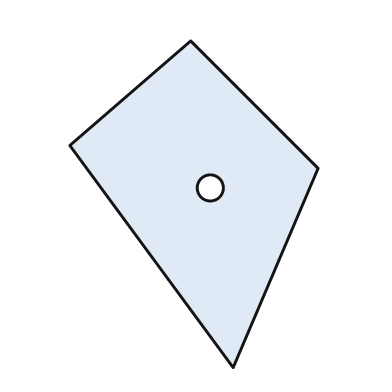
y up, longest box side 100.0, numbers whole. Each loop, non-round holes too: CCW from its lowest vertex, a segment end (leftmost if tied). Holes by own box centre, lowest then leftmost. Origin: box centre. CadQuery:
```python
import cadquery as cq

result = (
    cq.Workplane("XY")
    .moveTo(12.0, -50.0)
    .lineTo(38.0, 11.0)
    .lineTo(-1.0, 50.0)
    .lineTo(-38.0, 18.0)
    .close()
    .moveTo(5.0, 5.0)
    .circle(4.0)
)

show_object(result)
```